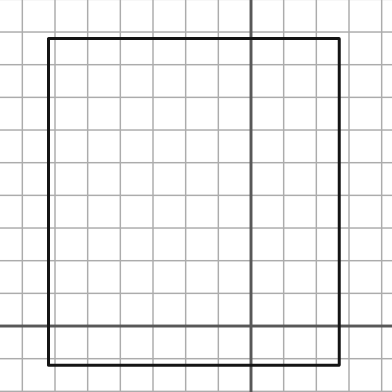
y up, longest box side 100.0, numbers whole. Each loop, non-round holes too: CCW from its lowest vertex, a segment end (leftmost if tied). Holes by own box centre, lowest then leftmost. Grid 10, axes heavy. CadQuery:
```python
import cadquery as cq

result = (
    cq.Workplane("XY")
    .moveTo(-62.0, -12.0)
    .lineTo(27.0, -12.0)
    .lineTo(27.0, 88.0)
    .lineTo(-62.0, 88.0)
    .close()
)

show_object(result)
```